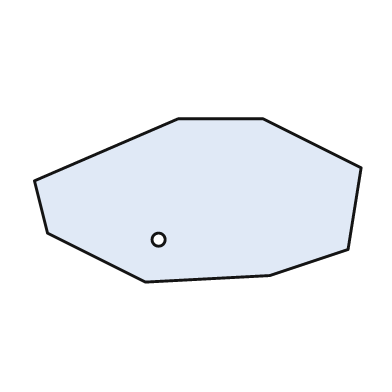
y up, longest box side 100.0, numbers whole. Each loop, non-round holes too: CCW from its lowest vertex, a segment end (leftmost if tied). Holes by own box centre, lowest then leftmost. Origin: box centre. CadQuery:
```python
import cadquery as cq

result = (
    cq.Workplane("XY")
    .moveTo(-16.0, -25.0)
    .lineTo(22.0, -23.0)
    .lineTo(46.0, -15.0)
    .lineTo(50.0, 10.0)
    .lineTo(20.0, 25.0)
    .lineTo(-6.0, 25.0)
    .lineTo(-50.0, 6.0)
    .lineTo(-46.0, -10.0)
    .close()
    .moveTo(-12.0, -12.0)
    .circle(2.0)
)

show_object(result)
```